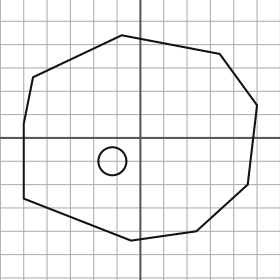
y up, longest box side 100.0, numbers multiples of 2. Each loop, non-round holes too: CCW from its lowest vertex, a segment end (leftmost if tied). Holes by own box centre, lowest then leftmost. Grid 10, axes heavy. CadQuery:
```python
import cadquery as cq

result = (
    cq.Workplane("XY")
    .moveTo(-4.0, -44.0)
    .lineTo(24.0, -40.0)
    .lineTo(46.0, -20.0)
    .lineTo(50.0, 14.0)
    .lineTo(34.0, 36.0)
    .lineTo(-8.0, 44.0)
    .lineTo(-46.0, 26.0)
    .lineTo(-50.0, 6.0)
    .lineTo(-50.0, -26.0)
    .close()
    .moveTo(-12.0, -10.0)
    .circle(6.0)
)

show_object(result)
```